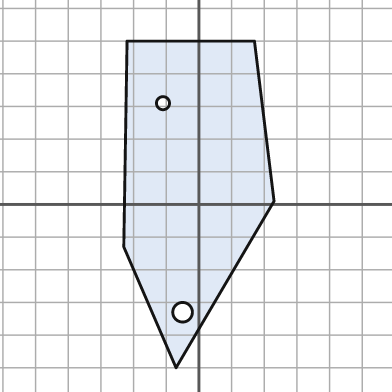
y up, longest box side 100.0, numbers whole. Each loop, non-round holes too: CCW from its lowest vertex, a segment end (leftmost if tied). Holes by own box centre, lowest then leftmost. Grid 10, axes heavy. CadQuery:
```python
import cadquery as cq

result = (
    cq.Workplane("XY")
    .moveTo(-7.0, -50.0)
    .lineTo(23.0, 1.0)
    .lineTo(17.0, 50.0)
    .lineTo(-22.0, 50.0)
    .lineTo(-23.0, -13.0)
    .close()
    .moveTo(-5.0, -33.0)
    .circle(3.0)
    .moveTo(-11.0, 31.0)
    .circle(2.0)
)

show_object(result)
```